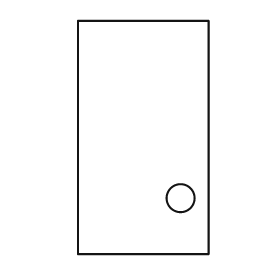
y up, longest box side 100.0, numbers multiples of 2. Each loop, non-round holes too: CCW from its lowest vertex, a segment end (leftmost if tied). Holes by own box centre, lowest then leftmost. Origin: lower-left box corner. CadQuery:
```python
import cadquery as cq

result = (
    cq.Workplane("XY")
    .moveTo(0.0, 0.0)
    .lineTo(56.0, 0.0)
    .lineTo(56.0, 100.0)
    .lineTo(0.0, 100.0)
    .close()
    .moveTo(44.0, 24.0)
    .circle(6.0)
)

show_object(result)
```